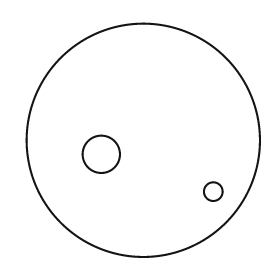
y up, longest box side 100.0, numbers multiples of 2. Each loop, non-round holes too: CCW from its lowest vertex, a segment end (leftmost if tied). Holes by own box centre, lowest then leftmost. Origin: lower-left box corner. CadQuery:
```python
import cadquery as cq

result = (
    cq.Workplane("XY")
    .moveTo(50.0, 50.0)
    .circle(50.0)
    .moveTo(80.0, 28.0)
    .circle(4.0)
    .moveTo(32.0, 44.0)
    .circle(8.0)
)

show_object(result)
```